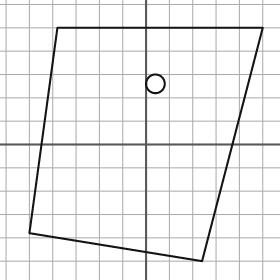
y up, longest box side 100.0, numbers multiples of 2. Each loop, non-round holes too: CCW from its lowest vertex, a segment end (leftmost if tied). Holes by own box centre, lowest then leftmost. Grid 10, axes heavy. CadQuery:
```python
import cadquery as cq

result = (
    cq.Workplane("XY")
    .moveTo(24.0, -50.0)
    .lineTo(50.0, 50.0)
    .lineTo(-38.0, 50.0)
    .lineTo(-50.0, -38.0)
    .close()
    .moveTo(4.0, 26.0)
    .circle(4.0)
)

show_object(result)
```